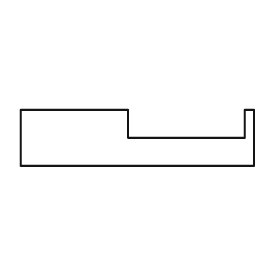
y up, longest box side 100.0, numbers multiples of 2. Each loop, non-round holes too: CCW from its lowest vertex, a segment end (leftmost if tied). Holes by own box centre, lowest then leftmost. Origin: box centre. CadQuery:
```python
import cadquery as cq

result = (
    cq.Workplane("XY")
    .moveTo(-50.0, -12.0)
    .lineTo(50.0, -12.0)
    .lineTo(50.0, 12.0)
    .lineTo(46.0, 12.0)
    .lineTo(46.0, 0.0)
    .lineTo(-4.0, 0.0)
    .lineTo(-4.0, 12.0)
    .lineTo(-50.0, 12.0)
    .close()
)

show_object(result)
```